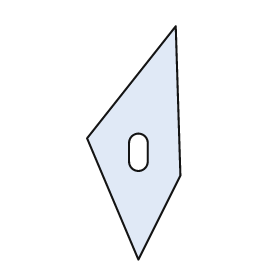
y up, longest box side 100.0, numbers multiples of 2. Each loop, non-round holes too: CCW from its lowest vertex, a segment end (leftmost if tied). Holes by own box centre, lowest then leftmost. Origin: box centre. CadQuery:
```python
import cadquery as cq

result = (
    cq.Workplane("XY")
    .moveTo(2.0, -50.0)
    .lineTo(20.0, -14.0)
    .lineTo(18.0, 50.0)
    .lineTo(-20.0, 2.0)
    .close()
    .moveTo(-2.0, -8.0)
    .threePointArc((2.0, -12.0), (6.0, -8.0))
    .lineTo(6.0, 0.0)
    .threePointArc((2.0, 4.0), (-2.0, 0.0))
    .close()
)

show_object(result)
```